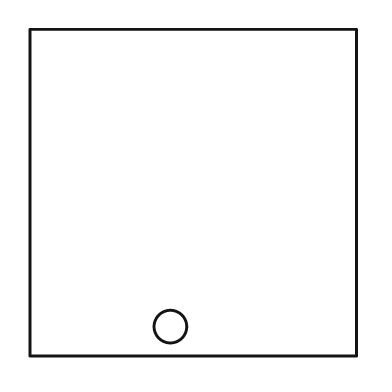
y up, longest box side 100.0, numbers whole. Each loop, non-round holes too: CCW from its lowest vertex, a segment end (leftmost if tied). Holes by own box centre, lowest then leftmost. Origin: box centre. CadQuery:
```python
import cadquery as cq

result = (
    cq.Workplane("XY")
    .moveTo(-50.0, -50.0)
    .lineTo(50.0, -50.0)
    .lineTo(50.0, 50.0)
    .lineTo(-50.0, 50.0)
    .close()
    .moveTo(-7.0, -41.0)
    .circle(5.0)
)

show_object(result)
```